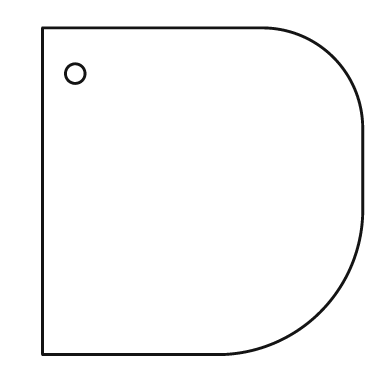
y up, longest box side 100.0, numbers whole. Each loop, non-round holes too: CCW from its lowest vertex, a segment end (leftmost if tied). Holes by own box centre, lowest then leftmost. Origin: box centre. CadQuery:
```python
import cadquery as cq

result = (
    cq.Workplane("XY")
    .moveTo(-49.0, -50.0)
    .lineTo(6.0, -50.0)
    .threePointArc((36.0, -37.0), (49.0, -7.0))
    .lineTo(49.0, 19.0)
    .threePointArc((40.0, 41.0), (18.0, 50.0))
    .lineTo(-49.0, 50.0)
    .close()
    .moveTo(-39.0, 36.0)
    .circle(3.0)
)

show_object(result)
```